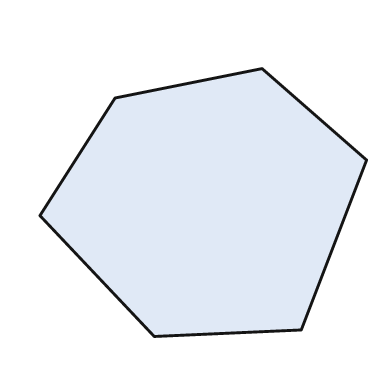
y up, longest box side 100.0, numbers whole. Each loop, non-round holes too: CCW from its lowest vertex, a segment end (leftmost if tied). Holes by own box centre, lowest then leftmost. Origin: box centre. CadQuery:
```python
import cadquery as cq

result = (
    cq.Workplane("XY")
    .moveTo(-15.0, -41.0)
    .lineTo(30.0, -39.0)
    .lineTo(50.0, 13.0)
    .lineTo(18.0, 41.0)
    .lineTo(-27.0, 32.0)
    .lineTo(-50.0, -4.0)
    .close()
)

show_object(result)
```